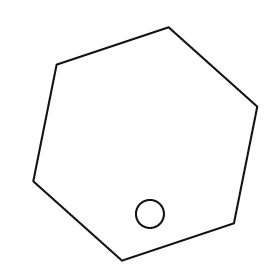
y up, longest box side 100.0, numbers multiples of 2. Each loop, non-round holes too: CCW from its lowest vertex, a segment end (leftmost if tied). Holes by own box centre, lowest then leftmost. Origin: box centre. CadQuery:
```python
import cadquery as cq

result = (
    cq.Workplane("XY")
    .moveTo(-10.0, -50.0)
    .lineTo(38.0, -34.0)
    .lineTo(48.0, 16.0)
    .lineTo(10.0, 50.0)
    .lineTo(-38.0, 34.0)
    .lineTo(-48.0, -16.0)
    .close()
    .moveTo(2.0, -30.0)
    .circle(6.0)
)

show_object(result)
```